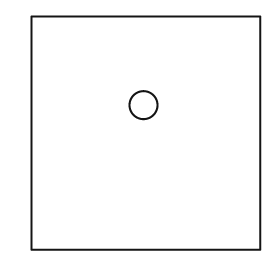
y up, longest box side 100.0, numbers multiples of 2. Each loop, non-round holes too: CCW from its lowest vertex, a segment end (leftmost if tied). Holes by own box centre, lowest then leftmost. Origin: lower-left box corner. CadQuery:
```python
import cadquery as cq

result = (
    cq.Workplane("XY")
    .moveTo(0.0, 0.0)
    .lineTo(98.0, 0.0)
    .lineTo(98.0, 100.0)
    .lineTo(0.0, 100.0)
    .close()
    .moveTo(48.0, 62.0)
    .circle(6.0)
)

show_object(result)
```